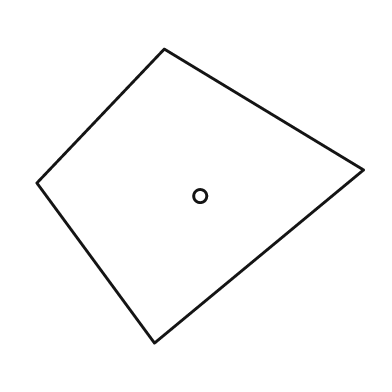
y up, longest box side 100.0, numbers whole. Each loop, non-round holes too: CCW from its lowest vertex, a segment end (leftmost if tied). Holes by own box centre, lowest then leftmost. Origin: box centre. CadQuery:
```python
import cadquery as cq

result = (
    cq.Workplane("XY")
    .moveTo(-14.0, -45.0)
    .lineTo(50.0, 8.0)
    .lineTo(-11.0, 45.0)
    .lineTo(-50.0, 4.0)
    .close()
    .moveTo(0.0, 0.0)
    .circle(2.0)
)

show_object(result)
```